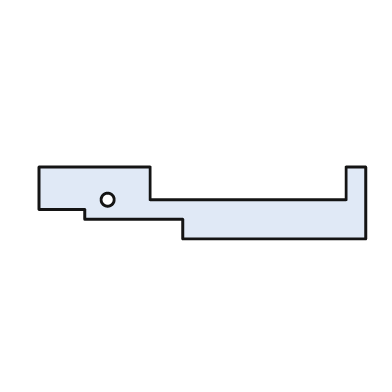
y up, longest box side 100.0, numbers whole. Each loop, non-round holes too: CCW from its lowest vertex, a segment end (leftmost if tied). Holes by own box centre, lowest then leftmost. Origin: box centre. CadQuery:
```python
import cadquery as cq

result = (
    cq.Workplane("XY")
    .moveTo(-6.0, -11.0)
    .lineTo(50.0, -11.0)
    .lineTo(50.0, 11.0)
    .lineTo(44.0, 11.0)
    .lineTo(44.0, 1.0)
    .lineTo(-16.0, 1.0)
    .lineTo(-16.0, 11.0)
    .lineTo(-50.0, 11.0)
    .lineTo(-50.0, -2.0)
    .lineTo(-36.0, -2.0)
    .lineTo(-36.0, -5.0)
    .lineTo(-6.0, -5.0)
    .close()
    .moveTo(-29.0, 1.0)
    .circle(2.0)
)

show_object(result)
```